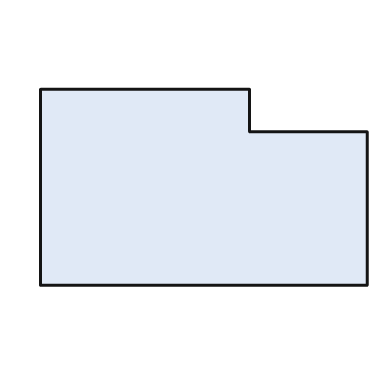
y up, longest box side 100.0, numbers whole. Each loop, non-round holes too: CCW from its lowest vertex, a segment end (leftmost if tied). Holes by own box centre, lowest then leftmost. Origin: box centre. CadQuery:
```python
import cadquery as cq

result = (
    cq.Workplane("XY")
    .moveTo(-50.0, -30.0)
    .lineTo(50.0, -30.0)
    .lineTo(50.0, 17.0)
    .lineTo(14.0, 17.0)
    .lineTo(14.0, 30.0)
    .lineTo(-50.0, 30.0)
    .close()
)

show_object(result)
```